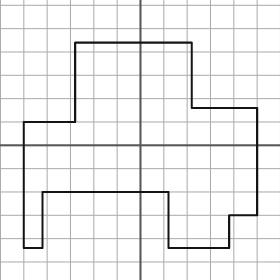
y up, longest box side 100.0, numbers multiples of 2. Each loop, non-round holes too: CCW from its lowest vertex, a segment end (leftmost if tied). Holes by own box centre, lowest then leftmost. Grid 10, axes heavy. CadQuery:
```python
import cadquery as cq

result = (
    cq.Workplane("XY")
    .moveTo(-50.0, -44.0)
    .lineTo(-42.0, -44.0)
    .lineTo(-42.0, -20.0)
    .lineTo(12.0, -20.0)
    .lineTo(12.0, -44.0)
    .lineTo(38.0, -44.0)
    .lineTo(38.0, -30.0)
    .lineTo(50.0, -30.0)
    .lineTo(50.0, 16.0)
    .lineTo(22.0, 16.0)
    .lineTo(22.0, 44.0)
    .lineTo(-28.0, 44.0)
    .lineTo(-28.0, 10.0)
    .lineTo(-50.0, 10.0)
    .close()
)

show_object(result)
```